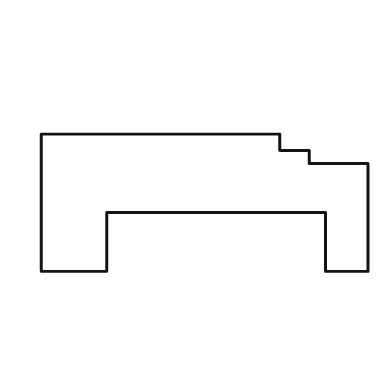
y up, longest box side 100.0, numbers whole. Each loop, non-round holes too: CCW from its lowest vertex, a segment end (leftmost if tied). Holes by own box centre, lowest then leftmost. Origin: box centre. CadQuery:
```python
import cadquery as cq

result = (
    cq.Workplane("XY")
    .moveTo(-50.0, -21.0)
    .lineTo(-30.0, -21.0)
    .lineTo(-30.0, -3.0)
    .lineTo(37.0, -3.0)
    .lineTo(37.0, -21.0)
    .lineTo(50.0, -21.0)
    .lineTo(50.0, 12.0)
    .lineTo(32.0, 12.0)
    .lineTo(32.0, 16.0)
    .lineTo(23.0, 16.0)
    .lineTo(23.0, 21.0)
    .lineTo(-50.0, 21.0)
    .close()
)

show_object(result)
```